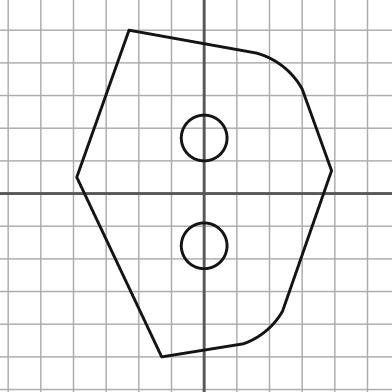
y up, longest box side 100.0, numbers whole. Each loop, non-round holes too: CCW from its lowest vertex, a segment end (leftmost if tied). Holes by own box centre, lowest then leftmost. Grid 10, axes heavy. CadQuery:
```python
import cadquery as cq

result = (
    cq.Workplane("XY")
    .moveTo(-13.0, -50.0)
    .lineTo(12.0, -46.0)
    .threePointArc((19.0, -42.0), (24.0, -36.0))
    .lineTo(39.0, 7.0)
    .lineTo(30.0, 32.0)
    .threePointArc((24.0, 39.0), (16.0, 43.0))
    .lineTo(-23.0, 50.0)
    .lineTo(-39.0, 5.0)
    .close()
    .moveTo(0.0, -16.0)
    .circle(7.0)
    .moveTo(0.0, 17.0)
    .circle(7.0)
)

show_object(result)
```